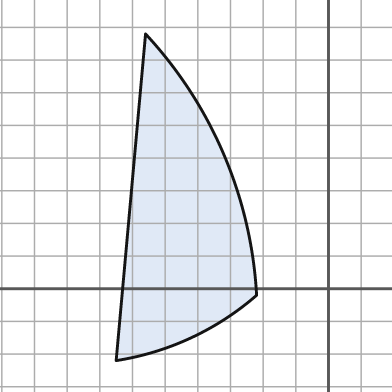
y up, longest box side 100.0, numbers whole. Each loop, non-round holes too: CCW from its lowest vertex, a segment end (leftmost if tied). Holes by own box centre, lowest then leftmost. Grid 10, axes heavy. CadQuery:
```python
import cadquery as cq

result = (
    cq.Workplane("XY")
    .moveTo(-65.0, -22.0)
    .threePointArc((-42.0, -15.0), (-22.0, -2.0))
    .threePointArc((-32.0, 41.0), (-56.0, 78.0))
    .close()
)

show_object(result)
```